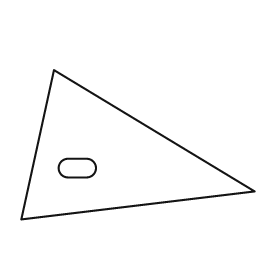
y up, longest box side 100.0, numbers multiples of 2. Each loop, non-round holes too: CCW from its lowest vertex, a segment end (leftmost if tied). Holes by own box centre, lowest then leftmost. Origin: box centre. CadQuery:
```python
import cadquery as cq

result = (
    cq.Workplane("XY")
    .moveTo(-50.0, -32.0)
    .lineTo(50.0, -20.0)
    .lineTo(-36.0, 32.0)
    .close()
    .moveTo(-30.0, -14.0)
    .lineTo(-22.0, -14.0)
    .threePointArc((-18.0, -10.0), (-22.0, -6.0))
    .lineTo(-30.0, -6.0)
    .threePointArc((-34.0, -10.0), (-30.0, -14.0))
    .close()
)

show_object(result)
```